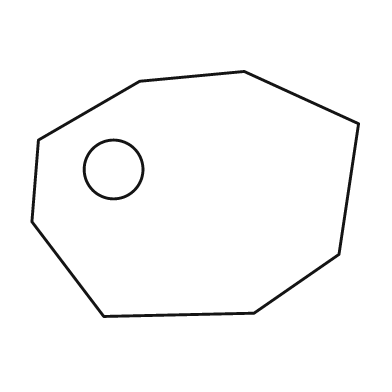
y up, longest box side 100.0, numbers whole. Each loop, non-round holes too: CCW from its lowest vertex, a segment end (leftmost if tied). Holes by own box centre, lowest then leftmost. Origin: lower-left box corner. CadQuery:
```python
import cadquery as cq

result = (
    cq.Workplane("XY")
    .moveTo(22.0, 0.0)
    .lineTo(68.0, 1.0)
    .lineTo(94.0, 19.0)
    .lineTo(100.0, 59.0)
    .lineTo(65.0, 75.0)
    .lineTo(33.0, 72.0)
    .lineTo(2.0, 54.0)
    .lineTo(0.0, 29.0)
    .close()
    .moveTo(25.0, 45.0)
    .circle(9.0)
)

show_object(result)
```